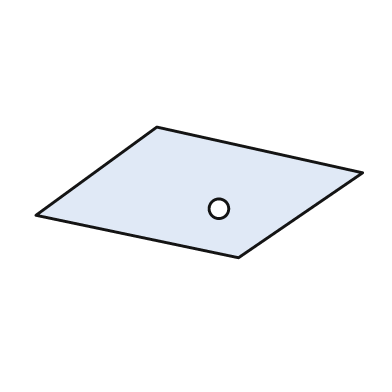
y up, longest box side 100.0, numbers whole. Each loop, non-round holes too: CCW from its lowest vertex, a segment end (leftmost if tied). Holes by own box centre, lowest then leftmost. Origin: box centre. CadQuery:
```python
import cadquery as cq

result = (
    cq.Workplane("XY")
    .moveTo(12.0, -20.0)
    .lineTo(50.0, 6.0)
    .lineTo(-13.0, 20.0)
    .lineTo(-50.0, -7.0)
    .close()
    .moveTo(6.0, -5.0)
    .circle(3.0)
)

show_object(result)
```